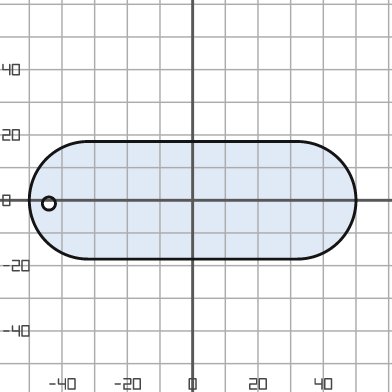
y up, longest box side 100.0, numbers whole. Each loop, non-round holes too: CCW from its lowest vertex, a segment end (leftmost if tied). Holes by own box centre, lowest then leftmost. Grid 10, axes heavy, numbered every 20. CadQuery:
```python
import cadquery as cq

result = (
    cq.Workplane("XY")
    .moveTo(-32.0, -18.0)
    .lineTo(32.0, -18.0)
    .threePointArc((50.0, 0.0), (32.0, 18.0))
    .lineTo(-32.0, 18.0)
    .threePointArc((-50.0, 0.0), (-32.0, -18.0))
    .close()
    .moveTo(-44.0, -1.0)
    .circle(2.0)
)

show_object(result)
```